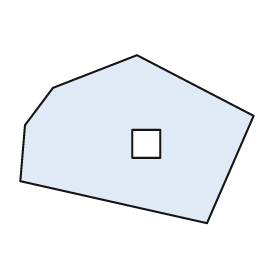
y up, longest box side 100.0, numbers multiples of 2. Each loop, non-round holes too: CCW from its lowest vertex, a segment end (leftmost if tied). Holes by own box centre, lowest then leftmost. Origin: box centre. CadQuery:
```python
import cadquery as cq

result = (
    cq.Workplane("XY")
    .moveTo(30.0, -36.0)
    .lineTo(50.0, 10.0)
    .lineTo(0.0, 36.0)
    .lineTo(-36.0, 22.0)
    .lineTo(-48.0, 6.0)
    .lineTo(-50.0, -18.0)
    .close()
    .moveTo(-2.0, -8.0)
    .lineTo(10.0, -8.0)
    .lineTo(10.0, 4.0)
    .lineTo(-2.0, 4.0)
    .close()
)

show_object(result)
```